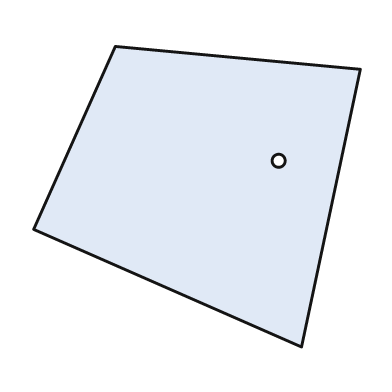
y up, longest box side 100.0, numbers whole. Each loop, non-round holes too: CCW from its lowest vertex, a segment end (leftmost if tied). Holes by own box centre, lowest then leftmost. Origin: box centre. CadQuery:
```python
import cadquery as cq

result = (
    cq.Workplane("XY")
    .moveTo(32.0, -46.0)
    .lineTo(50.0, 39.0)
    .lineTo(-25.0, 46.0)
    .lineTo(-50.0, -10.0)
    .close()
    .moveTo(25.0, 11.0)
    .circle(2.0)
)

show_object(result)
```